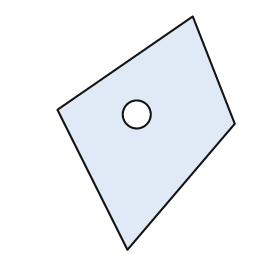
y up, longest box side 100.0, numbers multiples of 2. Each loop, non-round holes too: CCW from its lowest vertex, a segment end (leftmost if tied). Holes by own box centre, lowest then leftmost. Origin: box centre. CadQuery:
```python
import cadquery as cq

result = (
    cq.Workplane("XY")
    .moveTo(-8.0, -50.0)
    .lineTo(38.0, 4.0)
    .lineTo(20.0, 50.0)
    .lineTo(-38.0, 10.0)
    .close()
    .moveTo(-4.0, 8.0)
    .circle(6.0)
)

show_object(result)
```